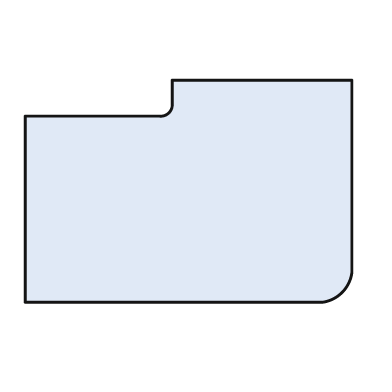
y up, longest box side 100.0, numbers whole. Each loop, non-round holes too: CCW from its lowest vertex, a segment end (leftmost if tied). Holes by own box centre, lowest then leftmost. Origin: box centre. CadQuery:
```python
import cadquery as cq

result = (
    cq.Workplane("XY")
    .moveTo(-50.0, -34.0)
    .lineTo(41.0, -34.0)
    .threePointArc((47.0, -31.0), (50.0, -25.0))
    .lineTo(50.0, 34.0)
    .lineTo(-5.0, 34.0)
    .lineTo(-5.0, 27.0)
    .threePointArc((-6.0, 24.0), (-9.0, 23.0))
    .lineTo(-50.0, 23.0)
    .close()
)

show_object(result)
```